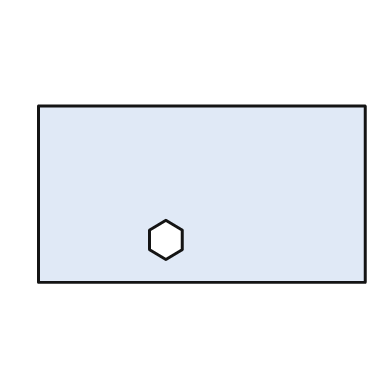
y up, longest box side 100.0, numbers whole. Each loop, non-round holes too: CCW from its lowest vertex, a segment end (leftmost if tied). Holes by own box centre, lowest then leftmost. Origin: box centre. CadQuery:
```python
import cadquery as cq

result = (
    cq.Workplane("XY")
    .moveTo(-50.0, -27.0)
    .lineTo(50.0, -27.0)
    .lineTo(50.0, 27.0)
    .lineTo(-50.0, 27.0)
    .close()
    .moveTo(-11.0, -20.0)
    .lineTo(-6.0, -17.0)
    .lineTo(-6.0, -11.0)
    .lineTo(-11.0, -8.0)
    .lineTo(-16.0, -11.0)
    .lineTo(-16.0, -17.0)
    .close()
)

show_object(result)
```